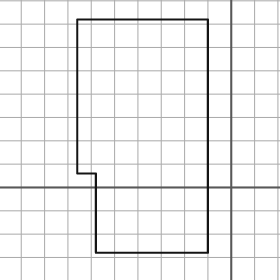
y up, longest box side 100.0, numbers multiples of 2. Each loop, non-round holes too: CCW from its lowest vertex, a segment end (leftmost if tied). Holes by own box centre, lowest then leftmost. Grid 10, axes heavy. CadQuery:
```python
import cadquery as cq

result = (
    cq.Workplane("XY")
    .moveTo(-58.0, -28.0)
    .lineTo(-10.0, -28.0)
    .lineTo(-10.0, 72.0)
    .lineTo(-66.0, 72.0)
    .lineTo(-66.0, 6.0)
    .lineTo(-58.0, 6.0)
    .close()
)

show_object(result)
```